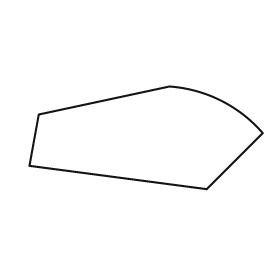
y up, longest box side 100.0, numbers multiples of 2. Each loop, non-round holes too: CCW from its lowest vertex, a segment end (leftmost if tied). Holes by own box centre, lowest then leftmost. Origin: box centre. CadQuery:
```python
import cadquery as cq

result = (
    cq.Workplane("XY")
    .moveTo(26.0, -22.0)
    .lineTo(50.0, 2.0)
    .threePointArc((32.0, 16.0), (10.0, 22.0))
    .lineTo(-46.0, 10.0)
    .lineTo(-50.0, -12.0)
    .close()
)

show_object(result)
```